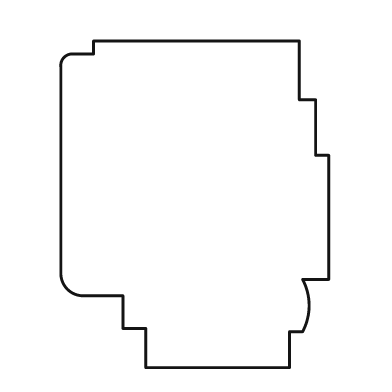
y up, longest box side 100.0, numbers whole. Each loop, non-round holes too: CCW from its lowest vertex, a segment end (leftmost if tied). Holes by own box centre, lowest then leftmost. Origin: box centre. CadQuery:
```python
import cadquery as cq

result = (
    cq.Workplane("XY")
    .moveTo(-15.0, -50.0)
    .lineTo(29.0, -50.0)
    .lineTo(29.0, -39.0)
    .lineTo(33.0, -39.0)
    .threePointArc((35.0, -31.0), (33.0, -23.0))
    .lineTo(41.0, -23.0)
    .lineTo(41.0, 15.0)
    .lineTo(37.0, 15.0)
    .lineTo(37.0, 32.0)
    .lineTo(32.0, 32.0)
    .lineTo(32.0, 50.0)
    .lineTo(-31.0, 50.0)
    .lineTo(-31.0, 46.0)
    .lineTo(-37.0, 46.0)
    .threePointArc((-40.0, 45.0), (-41.0, 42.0))
    .lineTo(-41.0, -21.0)
    .threePointArc((-39.0, -26.0), (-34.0, -28.0))
    .lineTo(-22.0, -28.0)
    .lineTo(-22.0, -38.0)
    .lineTo(-15.0, -38.0)
    .close()
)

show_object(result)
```